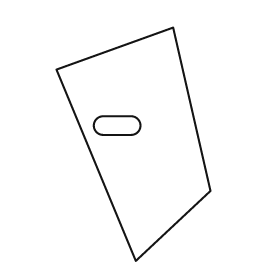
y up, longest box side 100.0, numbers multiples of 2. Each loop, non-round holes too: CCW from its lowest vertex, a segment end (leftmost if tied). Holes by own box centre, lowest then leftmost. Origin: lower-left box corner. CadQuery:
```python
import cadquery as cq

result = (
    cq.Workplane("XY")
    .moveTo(34.0, 0.0)
    .lineTo(66.0, 30.0)
    .lineTo(50.0, 100.0)
    .lineTo(0.0, 82.0)
    .close()
    .moveTo(20.0, 54.0)
    .lineTo(32.0, 54.0)
    .threePointArc((36.0, 58.0), (32.0, 62.0))
    .lineTo(20.0, 62.0)
    .threePointArc((16.0, 58.0), (20.0, 54.0))
    .close()
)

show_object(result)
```